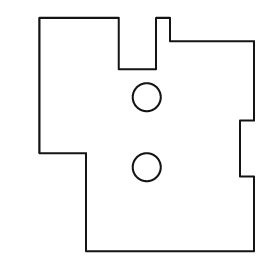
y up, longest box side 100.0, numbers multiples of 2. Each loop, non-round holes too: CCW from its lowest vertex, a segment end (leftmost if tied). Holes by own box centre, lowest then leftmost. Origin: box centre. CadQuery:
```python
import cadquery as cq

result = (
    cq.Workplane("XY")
    .moveTo(-26.0, -50.0)
    .lineTo(46.0, -50.0)
    .lineTo(46.0, -18.0)
    .lineTo(40.0, -18.0)
    .lineTo(40.0, 6.0)
    .lineTo(46.0, 6.0)
    .lineTo(46.0, 40.0)
    .lineTo(10.0, 40.0)
    .lineTo(10.0, 50.0)
    .lineTo(4.0, 50.0)
    .lineTo(4.0, 28.0)
    .lineTo(-12.0, 28.0)
    .lineTo(-12.0, 50.0)
    .lineTo(-46.0, 50.0)
    .lineTo(-46.0, -8.0)
    .lineTo(-26.0, -8.0)
    .close()
    .moveTo(0.0, -14.0)
    .circle(6.0)
    .moveTo(0.0, 16.0)
    .circle(6.0)
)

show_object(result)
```